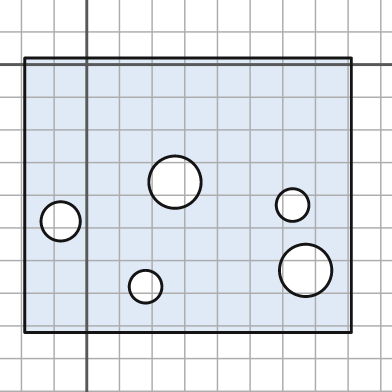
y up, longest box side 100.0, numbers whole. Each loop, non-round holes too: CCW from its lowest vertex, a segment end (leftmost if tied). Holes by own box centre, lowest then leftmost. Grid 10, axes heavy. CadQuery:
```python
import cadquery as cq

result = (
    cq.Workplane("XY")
    .moveTo(-19.0, -82.0)
    .lineTo(81.0, -82.0)
    .lineTo(81.0, 2.0)
    .lineTo(-19.0, 2.0)
    .close()
    .moveTo(18.0, -68.0)
    .circle(5.0)
    .moveTo(67.0, -63.0)
    .circle(8.0)
    .moveTo(-8.0, -48.0)
    .circle(6.0)
    .moveTo(63.0, -43.0)
    .circle(5.0)
    .moveTo(27.0, -36.0)
    .circle(8.0)
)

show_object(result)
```